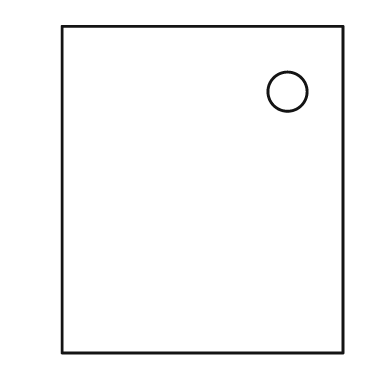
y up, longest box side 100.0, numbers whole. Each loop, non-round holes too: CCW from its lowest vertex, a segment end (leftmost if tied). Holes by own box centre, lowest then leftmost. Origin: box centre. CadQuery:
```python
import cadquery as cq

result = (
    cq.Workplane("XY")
    .moveTo(-43.0, -50.0)
    .lineTo(43.0, -50.0)
    .lineTo(43.0, 50.0)
    .lineTo(-43.0, 50.0)
    .close()
    .moveTo(26.0, 30.0)
    .circle(6.0)
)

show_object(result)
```